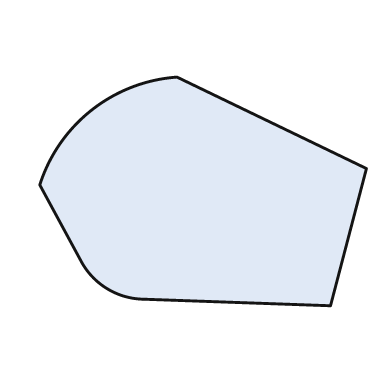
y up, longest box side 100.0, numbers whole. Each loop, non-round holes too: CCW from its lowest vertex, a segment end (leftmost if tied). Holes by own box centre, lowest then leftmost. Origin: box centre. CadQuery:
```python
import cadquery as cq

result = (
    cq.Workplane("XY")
    .moveTo(39.0, -35.0)
    .lineTo(50.0, 7.0)
    .lineTo(-8.0, 35.0)
    .threePointArc((-34.0, 25.0), (-50.0, 2.0))
    .lineTo(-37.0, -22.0)
    .threePointArc((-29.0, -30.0), (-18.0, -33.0))
    .close()
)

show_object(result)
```